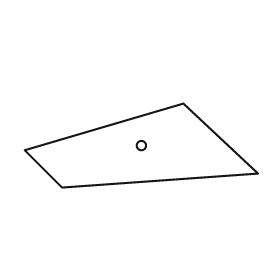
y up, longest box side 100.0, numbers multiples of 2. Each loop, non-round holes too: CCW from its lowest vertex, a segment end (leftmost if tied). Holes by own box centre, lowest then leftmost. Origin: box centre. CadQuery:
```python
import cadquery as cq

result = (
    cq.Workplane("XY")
    .moveTo(-34.0, -18.0)
    .lineTo(50.0, -12.0)
    .lineTo(18.0, 18.0)
    .lineTo(-50.0, -2.0)
    .close()
    .moveTo(0.0, 0.0)
    .circle(2.0)
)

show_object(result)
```